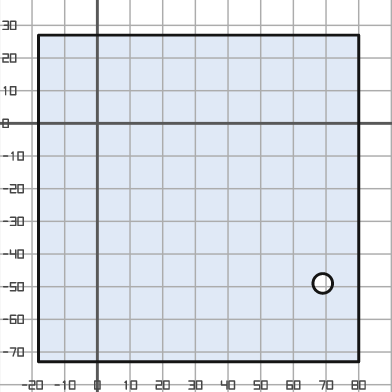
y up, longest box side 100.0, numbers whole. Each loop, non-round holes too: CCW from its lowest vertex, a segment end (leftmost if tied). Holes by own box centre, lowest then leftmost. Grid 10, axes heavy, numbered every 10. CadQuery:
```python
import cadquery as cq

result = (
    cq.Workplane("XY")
    .moveTo(-18.0, -73.0)
    .lineTo(80.0, -73.0)
    .lineTo(80.0, 27.0)
    .lineTo(-18.0, 27.0)
    .close()
    .moveTo(69.0, -49.0)
    .circle(3.0)
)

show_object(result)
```